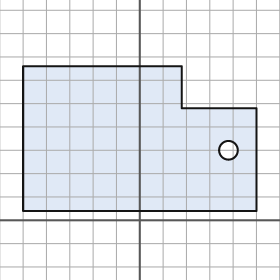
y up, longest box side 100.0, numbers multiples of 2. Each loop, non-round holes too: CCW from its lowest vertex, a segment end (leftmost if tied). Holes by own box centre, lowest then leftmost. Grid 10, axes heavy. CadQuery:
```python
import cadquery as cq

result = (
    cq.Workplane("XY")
    .moveTo(-50.0, 4.0)
    .lineTo(50.0, 4.0)
    .lineTo(50.0, 48.0)
    .lineTo(18.0, 48.0)
    .lineTo(18.0, 66.0)
    .lineTo(-50.0, 66.0)
    .close()
    .moveTo(38.0, 30.0)
    .circle(4.0)
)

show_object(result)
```